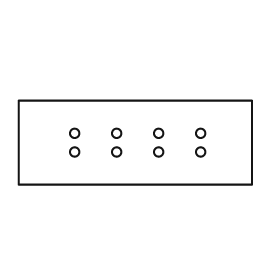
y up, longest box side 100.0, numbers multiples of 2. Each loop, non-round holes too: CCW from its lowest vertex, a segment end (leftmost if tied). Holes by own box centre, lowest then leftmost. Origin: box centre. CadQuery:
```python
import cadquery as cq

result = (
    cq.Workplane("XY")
    .moveTo(-50.0, -18.0)
    .lineTo(50.0, -18.0)
    .lineTo(50.0, 18.0)
    .lineTo(-50.0, 18.0)
    .close()
    .moveTo(-26.0, -4.0)
    .circle(2.0)
    .moveTo(-8.0, -4.0)
    .circle(2.0)
    .moveTo(10.0, -4.0)
    .circle(2.0)
    .moveTo(28.0, -4.0)
    .circle(2.0)
    .moveTo(-26.0, 4.0)
    .circle(2.0)
    .moveTo(-8.0, 4.0)
    .circle(2.0)
    .moveTo(10.0, 4.0)
    .circle(2.0)
    .moveTo(28.0, 4.0)
    .circle(2.0)
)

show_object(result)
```